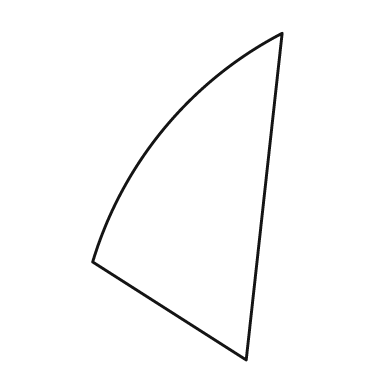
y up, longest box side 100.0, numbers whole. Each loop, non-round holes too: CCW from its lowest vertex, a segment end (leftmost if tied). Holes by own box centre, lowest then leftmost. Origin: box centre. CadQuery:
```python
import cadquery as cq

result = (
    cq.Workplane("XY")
    .moveTo(18.0, -50.0)
    .lineTo(29.0, 50.0)
    .threePointArc((-7.0, 21.0), (-29.0, -20.0))
    .close()
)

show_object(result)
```